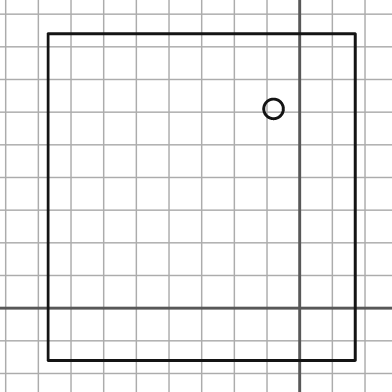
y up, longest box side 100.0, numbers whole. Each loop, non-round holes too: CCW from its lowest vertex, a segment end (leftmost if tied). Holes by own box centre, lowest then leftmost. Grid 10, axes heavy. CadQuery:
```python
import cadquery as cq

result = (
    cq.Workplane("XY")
    .moveTo(-77.0, -16.0)
    .lineTo(17.0, -16.0)
    .lineTo(17.0, 84.0)
    .lineTo(-77.0, 84.0)
    .close()
    .moveTo(-8.0, 61.0)
    .circle(3.0)
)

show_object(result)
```